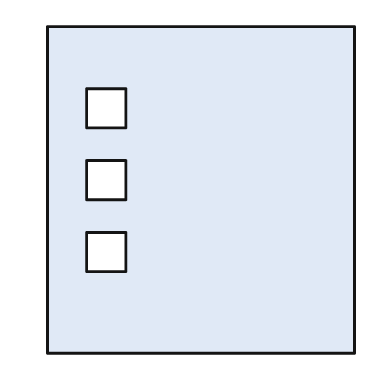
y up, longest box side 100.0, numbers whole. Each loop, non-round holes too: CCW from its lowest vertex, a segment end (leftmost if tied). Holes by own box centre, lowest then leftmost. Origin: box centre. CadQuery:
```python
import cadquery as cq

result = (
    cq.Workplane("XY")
    .moveTo(-47.0, -50.0)
    .lineTo(47.0, -50.0)
    .lineTo(47.0, 50.0)
    .lineTo(-47.0, 50.0)
    .close()
    .moveTo(-35.0, -25.0)
    .lineTo(-23.0, -25.0)
    .lineTo(-23.0, -13.0)
    .lineTo(-35.0, -13.0)
    .close()
    .moveTo(-35.0, -3.0)
    .lineTo(-23.0, -3.0)
    .lineTo(-23.0, 9.0)
    .lineTo(-35.0, 9.0)
    .close()
    .moveTo(-35.0, 19.0)
    .lineTo(-23.0, 19.0)
    .lineTo(-23.0, 31.0)
    .lineTo(-35.0, 31.0)
    .close()
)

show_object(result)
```